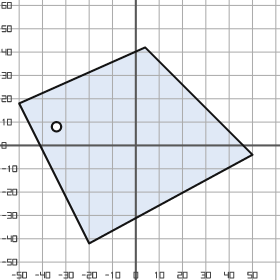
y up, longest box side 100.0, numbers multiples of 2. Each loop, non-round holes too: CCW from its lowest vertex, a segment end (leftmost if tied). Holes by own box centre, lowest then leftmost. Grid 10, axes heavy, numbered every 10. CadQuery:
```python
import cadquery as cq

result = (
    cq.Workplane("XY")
    .moveTo(-20.0, -42.0)
    .lineTo(50.0, -4.0)
    .lineTo(4.0, 42.0)
    .lineTo(-50.0, 18.0)
    .close()
    .moveTo(-34.0, 8.0)
    .circle(2.0)
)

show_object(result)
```